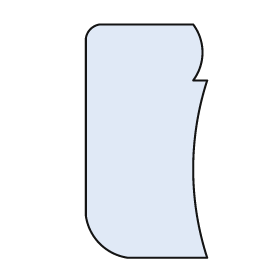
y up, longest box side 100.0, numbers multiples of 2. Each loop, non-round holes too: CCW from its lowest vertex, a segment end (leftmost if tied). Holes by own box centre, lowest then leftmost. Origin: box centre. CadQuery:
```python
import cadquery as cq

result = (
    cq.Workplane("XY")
    .moveTo(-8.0, -50.0)
    .lineTo(26.0, -50.0)
    .threePointArc((20.0, -12.0), (26.0, 26.0))
    .lineTo(20.0, 26.0)
    .threePointArc((24.0, 38.0), (20.0, 50.0))
    .lineTo(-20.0, 50.0)
    .threePointArc((-24.0, 48.0), (-26.0, 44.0))
    .lineTo(-26.0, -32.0)
    .threePointArc((-20.0, -44.0), (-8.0, -50.0))
    .close()
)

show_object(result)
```